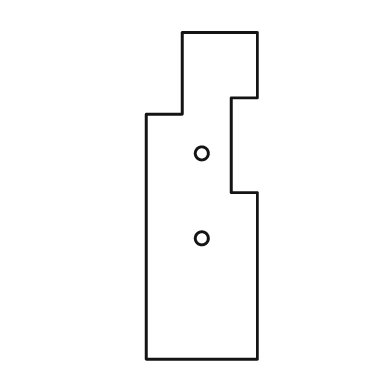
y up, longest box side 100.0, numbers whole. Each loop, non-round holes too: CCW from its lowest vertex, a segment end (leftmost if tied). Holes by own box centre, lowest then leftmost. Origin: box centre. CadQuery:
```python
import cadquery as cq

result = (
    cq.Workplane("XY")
    .moveTo(-17.0, -50.0)
    .lineTo(17.0, -50.0)
    .lineTo(17.0, 1.0)
    .lineTo(9.0, 1.0)
    .lineTo(9.0, 30.0)
    .lineTo(17.0, 30.0)
    .lineTo(17.0, 50.0)
    .lineTo(-6.0, 50.0)
    .lineTo(-6.0, 25.0)
    .lineTo(-17.0, 25.0)
    .close()
    .moveTo(0.0, -13.0)
    .circle(2.0)
    .moveTo(0.0, 13.0)
    .circle(2.0)
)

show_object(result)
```